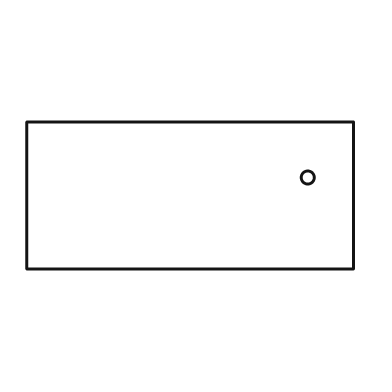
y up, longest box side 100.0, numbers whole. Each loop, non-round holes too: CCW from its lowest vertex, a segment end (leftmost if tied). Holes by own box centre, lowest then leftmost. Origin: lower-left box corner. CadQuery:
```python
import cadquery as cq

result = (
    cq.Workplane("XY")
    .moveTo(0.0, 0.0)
    .lineTo(100.0, 0.0)
    .lineTo(100.0, 45.0)
    .lineTo(0.0, 45.0)
    .close()
    .moveTo(86.0, 28.0)
    .circle(2.0)
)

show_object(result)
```